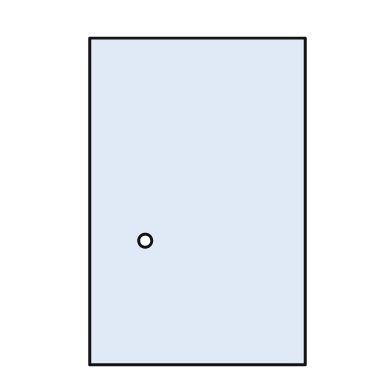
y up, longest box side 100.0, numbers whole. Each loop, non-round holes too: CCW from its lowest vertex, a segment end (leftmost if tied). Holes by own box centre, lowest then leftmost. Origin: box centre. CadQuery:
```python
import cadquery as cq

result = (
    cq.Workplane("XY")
    .moveTo(-33.0, -50.0)
    .lineTo(33.0, -50.0)
    .lineTo(33.0, 50.0)
    .lineTo(-33.0, 50.0)
    .close()
    .moveTo(-16.0, -12.0)
    .circle(2.0)
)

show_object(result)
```